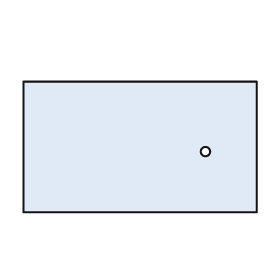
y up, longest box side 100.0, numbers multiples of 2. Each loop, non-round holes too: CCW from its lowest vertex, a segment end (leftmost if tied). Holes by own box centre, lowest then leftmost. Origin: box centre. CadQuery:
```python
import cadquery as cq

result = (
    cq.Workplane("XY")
    .moveTo(-50.0, -28.0)
    .lineTo(50.0, -28.0)
    .lineTo(50.0, 28.0)
    .lineTo(-50.0, 28.0)
    .close()
    .moveTo(28.0, -2.0)
    .circle(2.0)
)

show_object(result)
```